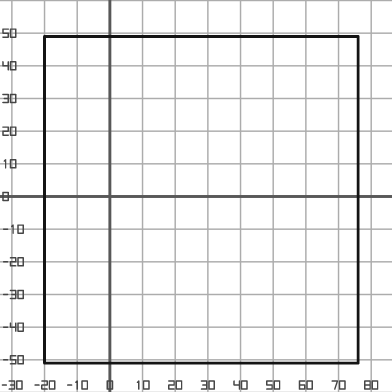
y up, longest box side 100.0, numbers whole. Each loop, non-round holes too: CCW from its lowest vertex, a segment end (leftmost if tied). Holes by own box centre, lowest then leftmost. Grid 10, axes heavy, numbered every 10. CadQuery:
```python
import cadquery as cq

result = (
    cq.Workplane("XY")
    .moveTo(-20.0, -51.0)
    .lineTo(76.0, -51.0)
    .lineTo(76.0, 49.0)
    .lineTo(-20.0, 49.0)
    .close()
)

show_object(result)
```